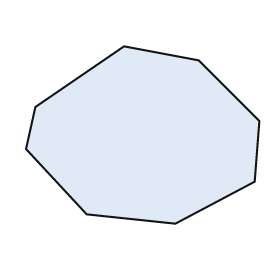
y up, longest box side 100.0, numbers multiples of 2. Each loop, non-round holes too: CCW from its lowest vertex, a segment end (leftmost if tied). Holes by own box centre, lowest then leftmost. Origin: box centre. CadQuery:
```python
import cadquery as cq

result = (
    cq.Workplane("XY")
    .moveTo(14.0, -38.0)
    .lineTo(48.0, -20.0)
    .lineTo(50.0, 6.0)
    .lineTo(24.0, 32.0)
    .lineTo(-8.0, 38.0)
    .lineTo(-46.0, 12.0)
    .lineTo(-50.0, -6.0)
    .lineTo(-24.0, -34.0)
    .close()
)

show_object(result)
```